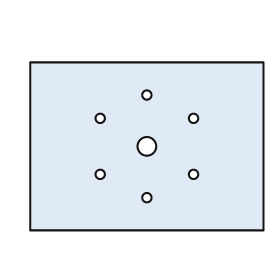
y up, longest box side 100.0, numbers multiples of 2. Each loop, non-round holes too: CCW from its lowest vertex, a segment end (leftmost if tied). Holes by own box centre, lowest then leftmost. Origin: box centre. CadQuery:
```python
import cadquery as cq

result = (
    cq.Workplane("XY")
    .moveTo(-50.0, -36.0)
    .lineTo(50.0, -36.0)
    .lineTo(50.0, 36.0)
    .lineTo(-50.0, 36.0)
    .close()
    .moveTo(0.0, -22.0)
    .circle(2.0)
    .moveTo(-20.0, -12.0)
    .circle(2.0)
    .moveTo(20.0, -12.0)
    .circle(2.0)
    .moveTo(0.0, 0.0)
    .circle(4.0)
    .moveTo(-20.0, 12.0)
    .circle(2.0)
    .moveTo(20.0, 12.0)
    .circle(2.0)
    .moveTo(0.0, 22.0)
    .circle(2.0)
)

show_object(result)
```